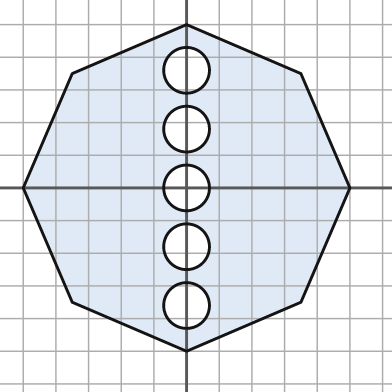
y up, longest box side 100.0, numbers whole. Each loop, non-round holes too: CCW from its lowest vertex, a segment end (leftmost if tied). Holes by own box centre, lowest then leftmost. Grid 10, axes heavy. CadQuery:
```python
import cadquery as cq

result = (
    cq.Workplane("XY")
    .moveTo(0.0, -50.0)
    .lineTo(35.0, -35.0)
    .lineTo(50.0, 0.0)
    .lineTo(35.0, 35.0)
    .lineTo(0.0, 50.0)
    .lineTo(-35.0, 35.0)
    .lineTo(-50.0, 0.0)
    .lineTo(-35.0, -35.0)
    .close()
    .moveTo(0.0, -36.0)
    .circle(7.0)
    .moveTo(0.0, -18.0)
    .circle(7.0)
    .moveTo(0.0, 0.0)
    .circle(7.0)
    .moveTo(0.0, 18.0)
    .circle(7.0)
    .moveTo(0.0, 36.0)
    .circle(7.0)
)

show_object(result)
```